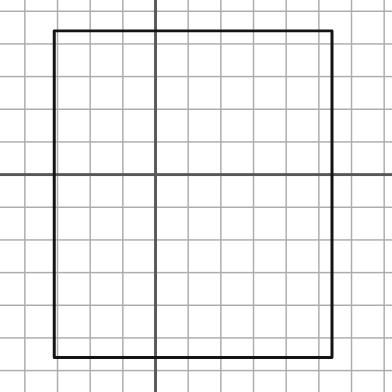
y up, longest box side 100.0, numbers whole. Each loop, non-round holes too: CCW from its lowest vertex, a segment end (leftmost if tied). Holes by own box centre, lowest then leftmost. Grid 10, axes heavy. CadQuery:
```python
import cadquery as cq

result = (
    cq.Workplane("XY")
    .moveTo(-31.0, -56.0)
    .lineTo(54.0, -56.0)
    .lineTo(54.0, 44.0)
    .lineTo(-31.0, 44.0)
    .close()
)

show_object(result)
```